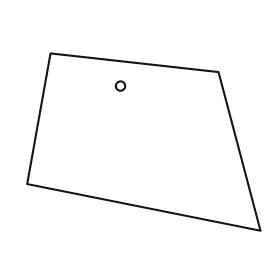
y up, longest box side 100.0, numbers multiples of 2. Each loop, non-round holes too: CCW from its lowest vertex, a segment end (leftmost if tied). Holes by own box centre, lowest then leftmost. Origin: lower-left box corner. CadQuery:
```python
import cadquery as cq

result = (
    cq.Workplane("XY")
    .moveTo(100.0, 0.0)
    .lineTo(82.0, 68.0)
    .lineTo(10.0, 76.0)
    .lineTo(0.0, 20.0)
    .close()
    .moveTo(40.0, 62.0)
    .circle(2.0)
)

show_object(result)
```